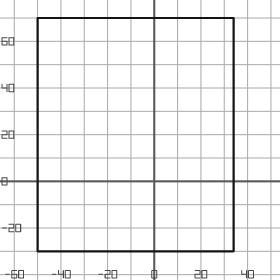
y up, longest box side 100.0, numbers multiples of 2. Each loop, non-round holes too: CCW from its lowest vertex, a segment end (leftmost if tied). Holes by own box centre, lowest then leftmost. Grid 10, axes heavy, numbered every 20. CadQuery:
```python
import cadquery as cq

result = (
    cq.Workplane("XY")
    .moveTo(-50.0, -30.0)
    .lineTo(34.0, -30.0)
    .lineTo(34.0, 70.0)
    .lineTo(-50.0, 70.0)
    .close()
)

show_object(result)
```